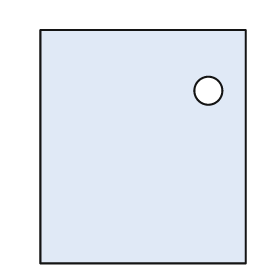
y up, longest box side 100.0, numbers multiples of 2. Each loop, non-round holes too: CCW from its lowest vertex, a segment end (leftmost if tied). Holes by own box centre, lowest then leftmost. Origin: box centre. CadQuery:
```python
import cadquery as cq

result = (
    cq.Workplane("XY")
    .moveTo(-44.0, -50.0)
    .lineTo(44.0, -50.0)
    .lineTo(44.0, 50.0)
    .lineTo(-44.0, 50.0)
    .close()
    .moveTo(28.0, 24.0)
    .circle(6.0)
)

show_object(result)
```